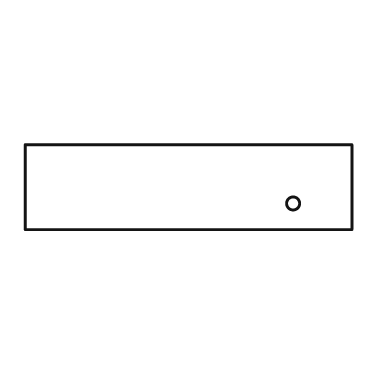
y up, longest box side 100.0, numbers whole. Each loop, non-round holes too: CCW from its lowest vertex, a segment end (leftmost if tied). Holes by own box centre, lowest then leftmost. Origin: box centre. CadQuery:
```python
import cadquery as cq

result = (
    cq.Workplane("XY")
    .moveTo(-50.0, -13.0)
    .lineTo(50.0, -13.0)
    .lineTo(50.0, 13.0)
    .lineTo(-50.0, 13.0)
    .close()
    .moveTo(32.0, -5.0)
    .circle(2.0)
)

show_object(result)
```